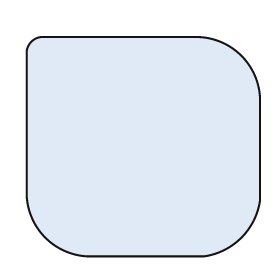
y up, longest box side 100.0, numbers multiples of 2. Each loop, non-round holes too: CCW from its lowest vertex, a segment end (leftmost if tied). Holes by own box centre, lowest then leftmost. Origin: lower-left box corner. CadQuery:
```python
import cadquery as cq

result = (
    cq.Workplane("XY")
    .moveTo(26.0, 0.0)
    .lineTo(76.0, 0.0)
    .threePointArc((92.0, 8.0), (100.0, 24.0))
    .lineTo(100.0, 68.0)
    .threePointArc((92.0, 86.0), (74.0, 94.0))
    .lineTo(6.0, 94.0)
    .threePointArc((2.0, 92.0), (0.0, 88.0))
    .lineTo(0.0, 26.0)
    .threePointArc((8.0, 8.0), (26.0, 0.0))
    .close()
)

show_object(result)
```